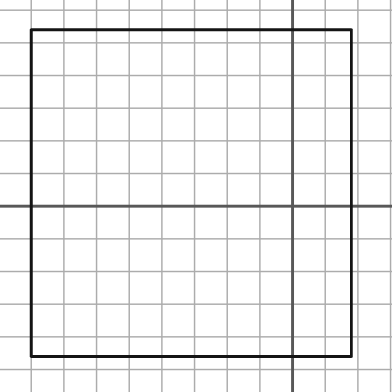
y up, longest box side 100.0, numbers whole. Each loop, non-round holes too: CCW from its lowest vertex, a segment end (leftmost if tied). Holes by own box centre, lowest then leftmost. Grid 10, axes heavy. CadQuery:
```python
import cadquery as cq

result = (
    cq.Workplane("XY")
    .moveTo(-80.0, -46.0)
    .lineTo(18.0, -46.0)
    .lineTo(18.0, 54.0)
    .lineTo(-80.0, 54.0)
    .close()
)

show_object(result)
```